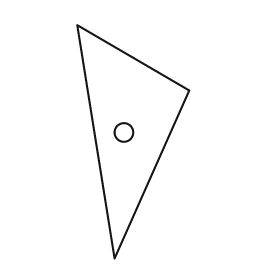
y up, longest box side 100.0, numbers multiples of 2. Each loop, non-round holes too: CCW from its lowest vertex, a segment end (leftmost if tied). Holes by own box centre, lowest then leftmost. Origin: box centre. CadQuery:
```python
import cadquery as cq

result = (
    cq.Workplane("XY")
    .moveTo(-8.0, -50.0)
    .lineTo(24.0, 22.0)
    .lineTo(-24.0, 50.0)
    .close()
    .moveTo(-4.0, 4.0)
    .circle(4.0)
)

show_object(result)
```